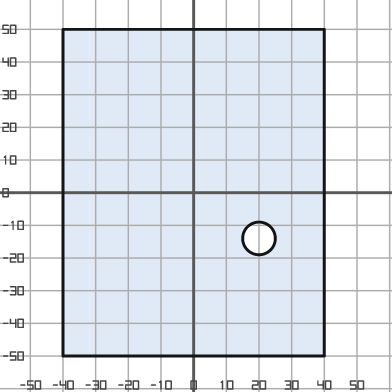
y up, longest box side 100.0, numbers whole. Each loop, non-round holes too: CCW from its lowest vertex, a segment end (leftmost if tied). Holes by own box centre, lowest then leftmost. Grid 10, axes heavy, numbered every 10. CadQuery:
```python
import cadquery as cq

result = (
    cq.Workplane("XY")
    .moveTo(-40.0, -50.0)
    .lineTo(40.0, -50.0)
    .lineTo(40.0, 50.0)
    .lineTo(-40.0, 50.0)
    .close()
    .moveTo(20.0, -14.0)
    .circle(5.0)
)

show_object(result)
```